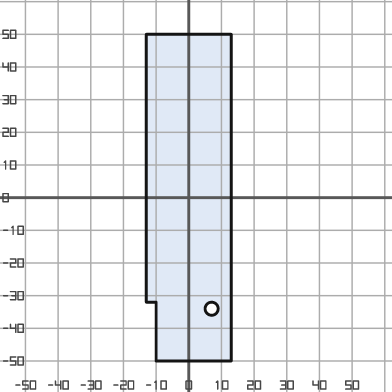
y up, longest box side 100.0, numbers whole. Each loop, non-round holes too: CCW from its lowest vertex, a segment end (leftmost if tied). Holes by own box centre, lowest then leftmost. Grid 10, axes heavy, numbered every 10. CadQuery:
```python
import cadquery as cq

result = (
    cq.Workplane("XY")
    .moveTo(-10.0, -50.0)
    .lineTo(13.0, -50.0)
    .lineTo(13.0, 50.0)
    .lineTo(-13.0, 50.0)
    .lineTo(-13.0, -32.0)
    .lineTo(-10.0, -32.0)
    .close()
    .moveTo(7.0, -34.0)
    .circle(2.0)
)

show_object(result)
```